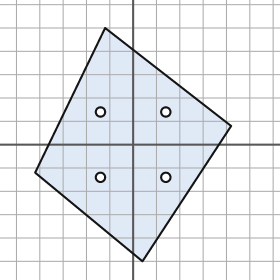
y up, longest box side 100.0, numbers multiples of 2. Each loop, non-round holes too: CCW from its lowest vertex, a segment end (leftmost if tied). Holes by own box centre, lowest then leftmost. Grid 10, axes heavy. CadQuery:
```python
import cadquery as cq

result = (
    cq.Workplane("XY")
    .moveTo(4.0, -50.0)
    .lineTo(42.0, 8.0)
    .lineTo(-12.0, 50.0)
    .lineTo(-42.0, -12.0)
    .close()
    .moveTo(-14.0, -14.0)
    .circle(2.0)
    .moveTo(14.0, -14.0)
    .circle(2.0)
    .moveTo(-14.0, 14.0)
    .circle(2.0)
    .moveTo(14.0, 14.0)
    .circle(2.0)
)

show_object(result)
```